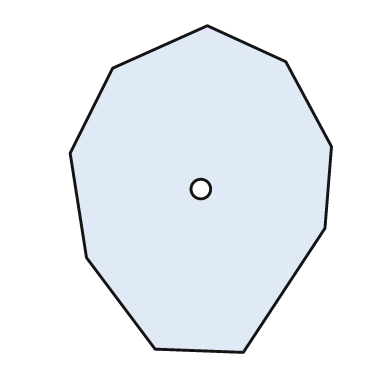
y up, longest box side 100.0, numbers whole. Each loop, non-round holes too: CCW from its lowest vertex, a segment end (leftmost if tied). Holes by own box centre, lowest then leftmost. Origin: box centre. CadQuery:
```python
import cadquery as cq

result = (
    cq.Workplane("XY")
    .moveTo(13.0, -50.0)
    .lineTo(38.0, -12.0)
    .lineTo(40.0, 13.0)
    .lineTo(26.0, 39.0)
    .lineTo(2.0, 50.0)
    .lineTo(-27.0, 37.0)
    .lineTo(-40.0, 11.0)
    .lineTo(-35.0, -21.0)
    .lineTo(-14.0, -49.0)
    .close()
    .moveTo(0.0, 0.0)
    .circle(3.0)
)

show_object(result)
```